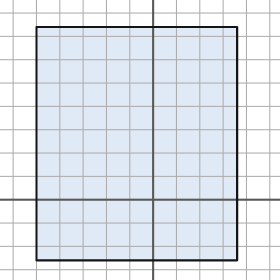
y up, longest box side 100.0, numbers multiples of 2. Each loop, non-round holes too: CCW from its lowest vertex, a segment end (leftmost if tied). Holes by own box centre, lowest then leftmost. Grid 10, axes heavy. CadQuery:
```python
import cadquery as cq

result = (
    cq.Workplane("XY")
    .moveTo(-50.0, -26.0)
    .lineTo(36.0, -26.0)
    .lineTo(36.0, 74.0)
    .lineTo(-50.0, 74.0)
    .close()
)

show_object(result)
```